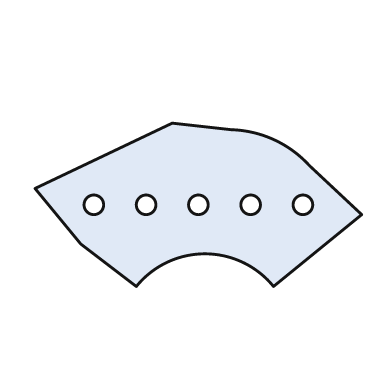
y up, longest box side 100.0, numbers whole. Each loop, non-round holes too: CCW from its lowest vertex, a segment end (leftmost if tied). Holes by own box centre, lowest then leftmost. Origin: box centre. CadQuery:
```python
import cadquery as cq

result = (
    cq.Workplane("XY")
    .moveTo(-19.0, -25.0)
    .threePointArc((2.0, -15.0), (23.0, -25.0))
    .lineTo(50.0, -3.0)
    .lineTo(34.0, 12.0)
    .threePointArc((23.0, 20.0), (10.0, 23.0))
    .lineTo(-8.0, 25.0)
    .lineTo(-50.0, 5.0)
    .lineTo(-36.0, -12.0)
    .close()
    .moveTo(-32.0, 0.0)
    .circle(3.0)
    .moveTo(-16.0, 0.0)
    .circle(3.0)
    .moveTo(0.0, 0.0)
    .circle(3.0)
    .moveTo(16.0, 0.0)
    .circle(3.0)
    .moveTo(32.0, 0.0)
    .circle(3.0)
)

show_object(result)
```